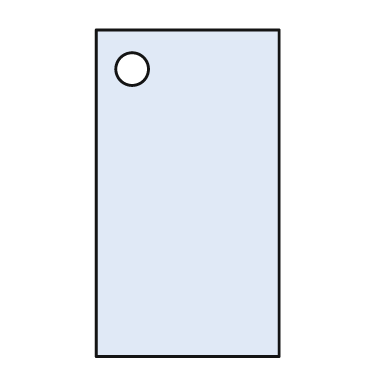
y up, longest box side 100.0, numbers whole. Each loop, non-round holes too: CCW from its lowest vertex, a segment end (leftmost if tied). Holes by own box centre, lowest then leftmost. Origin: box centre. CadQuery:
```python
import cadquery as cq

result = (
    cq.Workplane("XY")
    .moveTo(-28.0, -50.0)
    .lineTo(28.0, -50.0)
    .lineTo(28.0, 50.0)
    .lineTo(-28.0, 50.0)
    .close()
    .moveTo(-17.0, 38.0)
    .circle(5.0)
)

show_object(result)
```